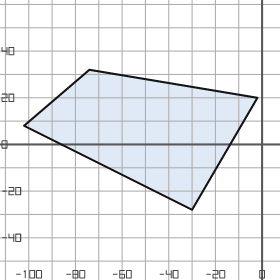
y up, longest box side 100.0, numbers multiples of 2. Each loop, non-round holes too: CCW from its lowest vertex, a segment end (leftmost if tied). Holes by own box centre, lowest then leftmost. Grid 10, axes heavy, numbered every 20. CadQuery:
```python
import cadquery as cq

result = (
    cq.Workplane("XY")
    .moveTo(-30.0, -28.0)
    .lineTo(-2.0, 20.0)
    .lineTo(-74.0, 32.0)
    .lineTo(-102.0, 8.0)
    .close()
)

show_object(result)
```